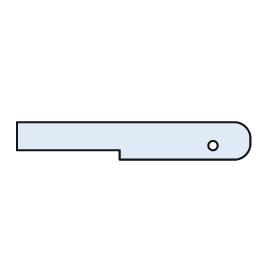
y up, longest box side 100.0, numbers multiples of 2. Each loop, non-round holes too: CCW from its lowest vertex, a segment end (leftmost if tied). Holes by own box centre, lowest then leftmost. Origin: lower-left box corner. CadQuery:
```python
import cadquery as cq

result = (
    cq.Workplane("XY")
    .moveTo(44.0, 0.0)
    .lineTo(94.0, 0.0)
    .threePointArc((98.0, 2.0), (100.0, 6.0))
    .lineTo(100.0, 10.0)
    .threePointArc((98.0, 14.0), (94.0, 16.0))
    .lineTo(0.0, 16.0)
    .lineTo(0.0, 4.0)
    .lineTo(44.0, 4.0)
    .close()
    .moveTo(84.0, 6.0)
    .circle(2.0)
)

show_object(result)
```